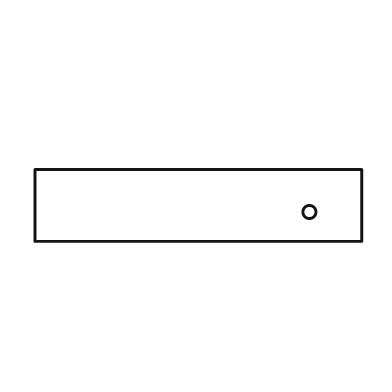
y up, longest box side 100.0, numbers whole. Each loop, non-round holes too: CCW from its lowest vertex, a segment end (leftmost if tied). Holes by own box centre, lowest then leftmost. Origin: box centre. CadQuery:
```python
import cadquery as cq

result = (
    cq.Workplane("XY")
    .moveTo(-50.0, -11.0)
    .lineTo(50.0, -11.0)
    .lineTo(50.0, 11.0)
    .lineTo(-50.0, 11.0)
    .close()
    .moveTo(34.0, -2.0)
    .circle(2.0)
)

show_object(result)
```